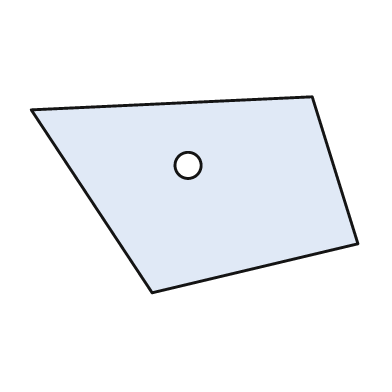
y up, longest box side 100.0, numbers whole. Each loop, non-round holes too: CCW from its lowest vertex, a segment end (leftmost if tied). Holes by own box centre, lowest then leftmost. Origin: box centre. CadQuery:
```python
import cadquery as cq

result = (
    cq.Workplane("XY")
    .moveTo(-13.0, -30.0)
    .lineTo(50.0, -15.0)
    .lineTo(36.0, 30.0)
    .lineTo(-50.0, 26.0)
    .close()
    .moveTo(-2.0, 9.0)
    .circle(4.0)
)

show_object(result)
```